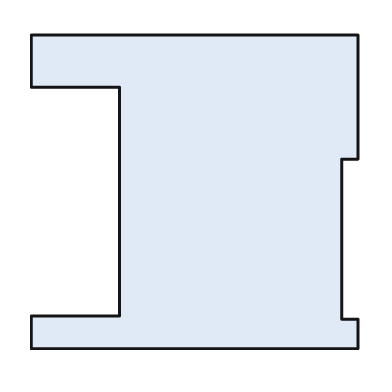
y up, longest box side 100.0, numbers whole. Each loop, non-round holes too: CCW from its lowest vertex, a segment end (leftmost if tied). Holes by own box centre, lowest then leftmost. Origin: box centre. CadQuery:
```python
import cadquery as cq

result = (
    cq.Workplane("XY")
    .moveTo(-50.0, -48.0)
    .lineTo(50.0, -48.0)
    .lineTo(50.0, -39.0)
    .lineTo(45.0, -39.0)
    .lineTo(45.0, 10.0)
    .lineTo(50.0, 10.0)
    .lineTo(50.0, 48.0)
    .lineTo(-50.0, 48.0)
    .lineTo(-50.0, 32.0)
    .lineTo(-23.0, 32.0)
    .lineTo(-23.0, -38.0)
    .lineTo(-50.0, -38.0)
    .close()
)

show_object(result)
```